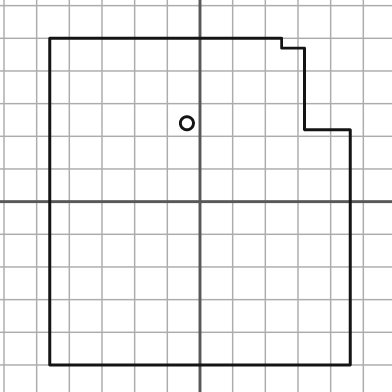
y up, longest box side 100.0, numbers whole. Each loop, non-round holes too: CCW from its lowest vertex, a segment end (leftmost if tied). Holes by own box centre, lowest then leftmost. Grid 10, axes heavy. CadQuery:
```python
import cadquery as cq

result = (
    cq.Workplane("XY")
    .moveTo(-46.0, -50.0)
    .lineTo(46.0, -50.0)
    .lineTo(46.0, 22.0)
    .lineTo(32.0, 22.0)
    .lineTo(32.0, 47.0)
    .lineTo(25.0, 47.0)
    .lineTo(25.0, 50.0)
    .lineTo(-46.0, 50.0)
    .close()
    .moveTo(-4.0, 24.0)
    .circle(2.0)
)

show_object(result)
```